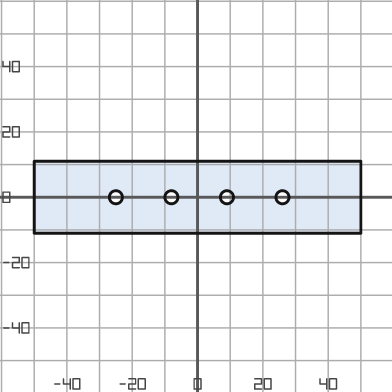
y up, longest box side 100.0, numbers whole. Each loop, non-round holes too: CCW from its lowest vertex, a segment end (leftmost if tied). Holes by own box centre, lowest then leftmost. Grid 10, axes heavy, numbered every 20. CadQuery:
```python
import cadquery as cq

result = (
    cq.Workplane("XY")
    .moveTo(-50.0, -11.0)
    .lineTo(50.0, -11.0)
    .lineTo(50.0, 11.0)
    .lineTo(-50.0, 11.0)
    .close()
    .moveTo(-25.0, 0.0)
    .circle(2.0)
    .moveTo(-8.0, 0.0)
    .circle(2.0)
    .moveTo(9.0, 0.0)
    .circle(2.0)
    .moveTo(26.0, 0.0)
    .circle(2.0)
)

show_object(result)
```